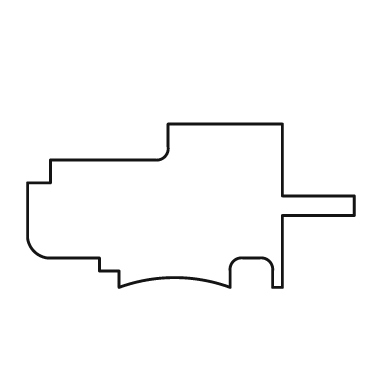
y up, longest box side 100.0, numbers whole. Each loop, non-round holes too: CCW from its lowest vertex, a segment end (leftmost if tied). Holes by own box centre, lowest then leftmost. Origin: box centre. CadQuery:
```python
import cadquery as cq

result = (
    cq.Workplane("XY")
    .moveTo(-22.0, -25.0)
    .threePointArc((-5.0, -22.0), (12.0, -25.0))
    .lineTo(12.0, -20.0)
    .threePointArc((13.0, -17.0), (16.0, -16.0))
    .lineTo(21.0, -16.0)
    .threePointArc((24.0, -17.0), (25.0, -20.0))
    .lineTo(25.0, -25.0)
    .lineTo(28.0, -25.0)
    .lineTo(28.0, -3.0)
    .lineTo(50.0, -3.0)
    .lineTo(50.0, 3.0)
    .lineTo(28.0, 3.0)
    .lineTo(28.0, 25.0)
    .lineTo(-7.0, 25.0)
    .lineTo(-7.0, 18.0)
    .threePointArc((-8.0, 15.0), (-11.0, 14.0))
    .lineTo(-43.0, 14.0)
    .lineTo(-43.0, 7.0)
    .lineTo(-50.0, 7.0)
    .lineTo(-50.0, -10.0)
    .threePointArc((-48.0, -14.0), (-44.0, -16.0))
    .lineTo(-28.0, -16.0)
    .lineTo(-28.0, -20.0)
    .lineTo(-22.0, -20.0)
    .close()
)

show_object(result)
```